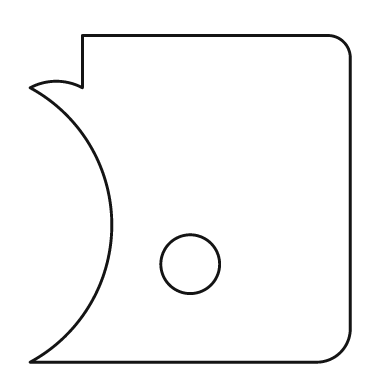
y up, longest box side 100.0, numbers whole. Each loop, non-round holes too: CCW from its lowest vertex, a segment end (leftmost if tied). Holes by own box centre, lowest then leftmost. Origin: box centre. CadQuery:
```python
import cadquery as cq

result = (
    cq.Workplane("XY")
    .moveTo(-49.0, -50.0)
    .lineTo(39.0, -50.0)
    .threePointArc((46.0, -47.0), (49.0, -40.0))
    .lineTo(49.0, 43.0)
    .threePointArc((47.0, 48.0), (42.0, 50.0))
    .lineTo(-33.0, 50.0)
    .lineTo(-33.0, 34.0)
    .threePointArc((-41.0, 36.0), (-49.0, 34.0))
    .threePointArc((-24.0, -8.0), (-49.0, -50.0))
    .close()
    .moveTo(0.0, -20.0)
    .circle(9.0)
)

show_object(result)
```